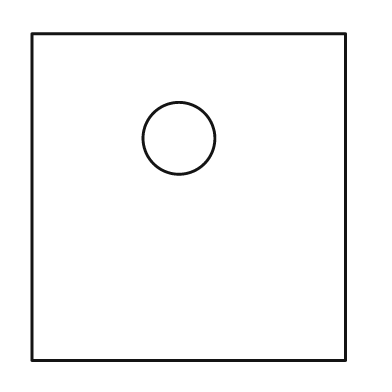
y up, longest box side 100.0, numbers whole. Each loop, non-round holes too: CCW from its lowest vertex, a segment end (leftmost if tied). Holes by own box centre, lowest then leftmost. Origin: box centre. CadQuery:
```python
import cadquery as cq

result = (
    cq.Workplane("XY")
    .moveTo(-48.0, -50.0)
    .lineTo(48.0, -50.0)
    .lineTo(48.0, 50.0)
    .lineTo(-48.0, 50.0)
    .close()
    .moveTo(-3.0, 18.0)
    .circle(11.0)
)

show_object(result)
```